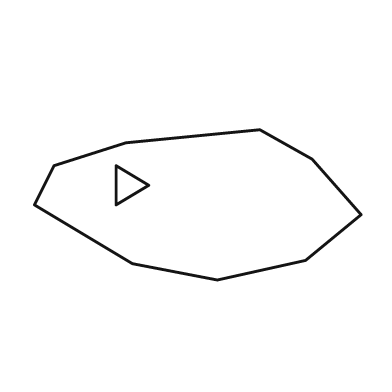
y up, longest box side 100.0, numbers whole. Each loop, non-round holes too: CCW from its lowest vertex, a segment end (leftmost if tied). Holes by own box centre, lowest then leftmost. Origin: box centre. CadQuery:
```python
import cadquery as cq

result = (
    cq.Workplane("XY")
    .moveTo(6.0, -23.0)
    .lineTo(33.0, -17.0)
    .lineTo(50.0, -3.0)
    .lineTo(35.0, 14.0)
    .lineTo(19.0, 23.0)
    .lineTo(-22.0, 19.0)
    .lineTo(-44.0, 12.0)
    .lineTo(-50.0, 0.0)
    .lineTo(-20.0, -18.0)
    .close()
    .moveTo(-25.0, 0.0)
    .lineTo(-15.0, 6.0)
    .lineTo(-25.0, 12.0)
    .close()
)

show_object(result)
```